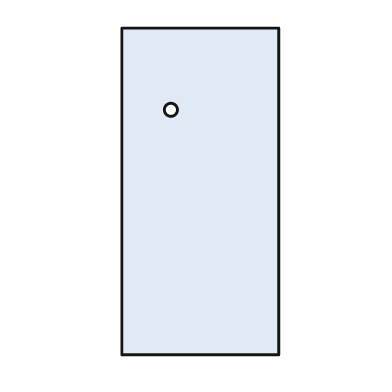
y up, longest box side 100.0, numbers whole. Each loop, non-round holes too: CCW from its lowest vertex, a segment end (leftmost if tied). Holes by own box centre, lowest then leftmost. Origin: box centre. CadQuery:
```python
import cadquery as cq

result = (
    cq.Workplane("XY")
    .moveTo(-24.0, -50.0)
    .lineTo(24.0, -50.0)
    .lineTo(24.0, 50.0)
    .lineTo(-24.0, 50.0)
    .close()
    .moveTo(-9.0, 25.0)
    .circle(2.0)
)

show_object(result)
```